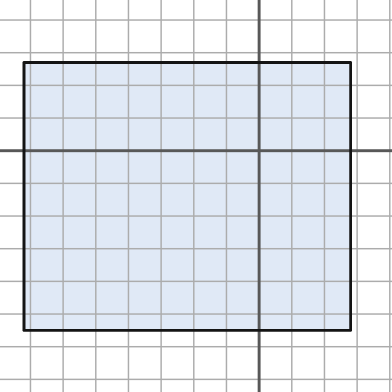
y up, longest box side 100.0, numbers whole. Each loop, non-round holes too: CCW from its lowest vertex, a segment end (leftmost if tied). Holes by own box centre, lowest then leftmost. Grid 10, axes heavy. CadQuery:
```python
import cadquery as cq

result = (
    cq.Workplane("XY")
    .moveTo(-72.0, -55.0)
    .lineTo(28.0, -55.0)
    .lineTo(28.0, 27.0)
    .lineTo(-72.0, 27.0)
    .close()
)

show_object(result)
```